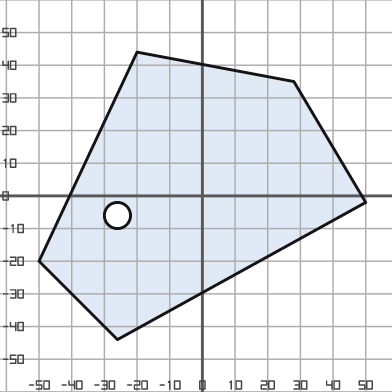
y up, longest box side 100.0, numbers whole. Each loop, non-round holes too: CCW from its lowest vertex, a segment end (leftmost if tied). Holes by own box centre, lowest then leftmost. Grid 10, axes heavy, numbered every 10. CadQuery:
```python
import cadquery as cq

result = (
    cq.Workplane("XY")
    .moveTo(-26.0, -44.0)
    .lineTo(50.0, -2.0)
    .lineTo(28.0, 35.0)
    .lineTo(-20.0, 44.0)
    .lineTo(-50.0, -20.0)
    .close()
    .moveTo(-26.0, -6.0)
    .circle(4.0)
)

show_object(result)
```